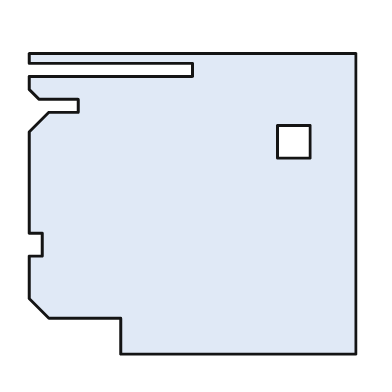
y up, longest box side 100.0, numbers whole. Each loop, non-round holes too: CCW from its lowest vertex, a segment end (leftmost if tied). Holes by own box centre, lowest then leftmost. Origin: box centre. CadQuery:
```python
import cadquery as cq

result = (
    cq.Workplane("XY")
    .moveTo(-22.0, -46.0)
    .lineTo(50.0, -46.0)
    .lineTo(50.0, 46.0)
    .lineTo(-50.0, 46.0)
    .lineTo(-50.0, 43.0)
    .lineTo(0.0, 43.0)
    .lineTo(0.0, 39.0)
    .lineTo(-50.0, 39.0)
    .lineTo(-50.0, 35.0)
    .lineTo(-47.0, 32.0)
    .lineTo(-35.0, 32.0)
    .lineTo(-35.0, 28.0)
    .lineTo(-44.0, 28.0)
    .lineTo(-50.0, 22.0)
    .lineTo(-50.0, -9.0)
    .lineTo(-46.0, -9.0)
    .lineTo(-46.0, -16.0)
    .lineTo(-50.0, -16.0)
    .lineTo(-50.0, -29.0)
    .lineTo(-44.0, -35.0)
    .lineTo(-22.0, -35.0)
    .close()
    .moveTo(26.0, 14.0)
    .lineTo(36.0, 14.0)
    .lineTo(36.0, 24.0)
    .lineTo(26.0, 24.0)
    .close()
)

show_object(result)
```